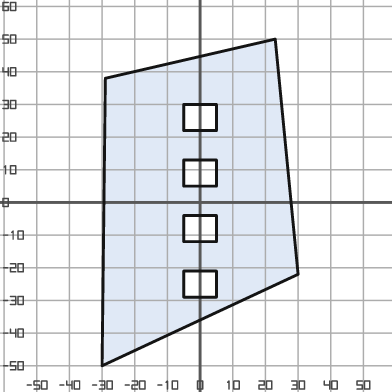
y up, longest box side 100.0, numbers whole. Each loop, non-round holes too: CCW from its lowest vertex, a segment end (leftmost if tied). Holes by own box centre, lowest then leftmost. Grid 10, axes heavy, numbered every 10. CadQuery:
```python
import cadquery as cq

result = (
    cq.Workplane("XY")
    .moveTo(-30.0, -50.0)
    .lineTo(30.0, -22.0)
    .lineTo(23.0, 50.0)
    .lineTo(-29.0, 38.0)
    .close()
    .moveTo(-5.0, -29.0)
    .lineTo(5.0, -29.0)
    .lineTo(5.0, -21.0)
    .lineTo(-5.0, -21.0)
    .close()
    .moveTo(-5.0, -12.0)
    .lineTo(5.0, -12.0)
    .lineTo(5.0, -4.0)
    .lineTo(-5.0, -4.0)
    .close()
    .moveTo(-5.0, 5.0)
    .lineTo(5.0, 5.0)
    .lineTo(5.0, 13.0)
    .lineTo(-5.0, 13.0)
    .close()
    .moveTo(-5.0, 22.0)
    .lineTo(5.0, 22.0)
    .lineTo(5.0, 30.0)
    .lineTo(-5.0, 30.0)
    .close()
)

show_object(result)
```